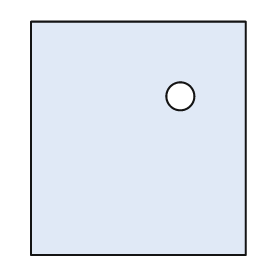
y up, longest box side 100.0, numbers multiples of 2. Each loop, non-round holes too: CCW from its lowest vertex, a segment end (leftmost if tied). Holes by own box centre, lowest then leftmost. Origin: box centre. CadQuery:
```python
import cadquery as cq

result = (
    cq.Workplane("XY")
    .moveTo(-46.0, -50.0)
    .lineTo(46.0, -50.0)
    .lineTo(46.0, 50.0)
    .lineTo(-46.0, 50.0)
    .close()
    .moveTo(18.0, 18.0)
    .circle(6.0)
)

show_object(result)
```